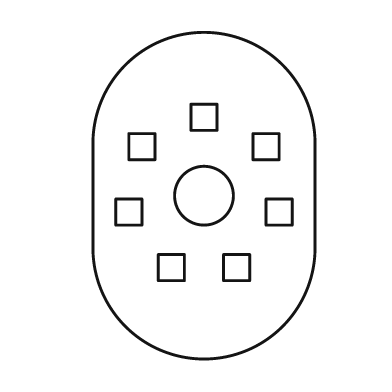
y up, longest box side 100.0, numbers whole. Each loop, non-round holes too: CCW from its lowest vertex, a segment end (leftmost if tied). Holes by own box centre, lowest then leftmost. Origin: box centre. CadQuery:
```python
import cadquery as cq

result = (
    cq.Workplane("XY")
    .moveTo(-34.0, -16.0)
    .threePointArc((0.0, -50.0), (34.0, -16.0))
    .lineTo(34.0, 16.0)
    .threePointArc((0.0, 50.0), (-34.0, 16.0))
    .close()
    .moveTo(-14.0, -26.0)
    .lineTo(-6.0, -26.0)
    .lineTo(-6.0, -18.0)
    .lineTo(-14.0, -18.0)
    .close()
    .moveTo(6.0, -26.0)
    .lineTo(14.0, -26.0)
    .lineTo(14.0, -18.0)
    .lineTo(6.0, -18.0)
    .close()
    .moveTo(-27.0, -9.0)
    .lineTo(-19.0, -9.0)
    .lineTo(-19.0, -1.0)
    .lineTo(-27.0, -1.0)
    .close()
    .moveTo(19.0, -9.0)
    .lineTo(27.0, -9.0)
    .lineTo(27.0, -1.0)
    .lineTo(19.0, -1.0)
    .close()
    .moveTo(0.0, 0.0)
    .circle(9.0)
    .moveTo(-23.0, 11.0)
    .lineTo(-15.0, 11.0)
    .lineTo(-15.0, 19.0)
    .lineTo(-23.0, 19.0)
    .close()
    .moveTo(15.0, 11.0)
    .lineTo(23.0, 11.0)
    .lineTo(23.0, 19.0)
    .lineTo(15.0, 19.0)
    .close()
    .moveTo(-4.0, 20.0)
    .lineTo(4.0, 20.0)
    .lineTo(4.0, 28.0)
    .lineTo(-4.0, 28.0)
    .close()
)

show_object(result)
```